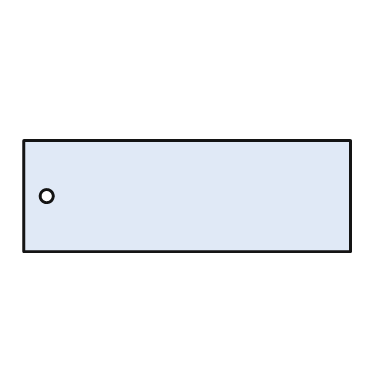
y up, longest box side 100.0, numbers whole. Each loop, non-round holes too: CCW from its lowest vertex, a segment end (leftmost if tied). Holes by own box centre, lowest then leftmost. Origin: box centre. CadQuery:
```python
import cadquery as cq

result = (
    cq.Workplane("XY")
    .moveTo(-50.0, -17.0)
    .lineTo(50.0, -17.0)
    .lineTo(50.0, 17.0)
    .lineTo(-50.0, 17.0)
    .close()
    .moveTo(-43.0, 0.0)
    .circle(2.0)
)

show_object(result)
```